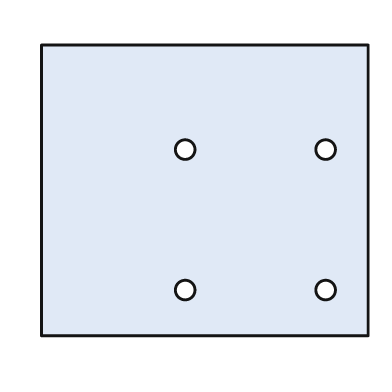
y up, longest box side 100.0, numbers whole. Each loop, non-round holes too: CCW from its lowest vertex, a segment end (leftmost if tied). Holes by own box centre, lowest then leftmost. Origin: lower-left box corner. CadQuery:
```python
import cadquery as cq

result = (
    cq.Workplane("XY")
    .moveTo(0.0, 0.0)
    .lineTo(100.0, 0.0)
    .lineTo(100.0, 89.0)
    .lineTo(0.0, 89.0)
    .close()
    .moveTo(44.0, 14.0)
    .circle(3.0)
    .moveTo(87.0, 14.0)
    .circle(3.0)
    .moveTo(44.0, 57.0)
    .circle(3.0)
    .moveTo(87.0, 57.0)
    .circle(3.0)
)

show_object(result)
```